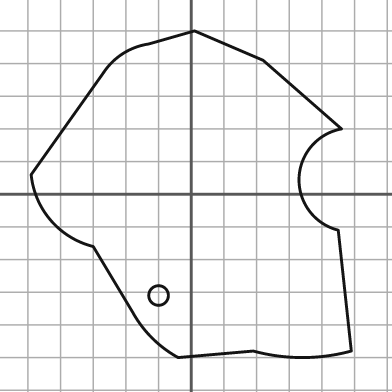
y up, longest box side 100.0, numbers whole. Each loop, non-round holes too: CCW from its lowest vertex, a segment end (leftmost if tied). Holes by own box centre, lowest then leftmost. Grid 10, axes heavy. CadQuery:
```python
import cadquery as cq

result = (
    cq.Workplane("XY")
    .moveTo(-4.0, -50.0)
    .lineTo(19.0, -48.0)
    .threePointArc((34.0, -50.0), (49.0, -48.0))
    .lineTo(45.0, -11.0)
    .threePointArc((33.0, 5.0), (46.0, 20.0))
    .lineTo(22.0, 41.0)
    .lineTo(1.0, 50.0)
    .lineTo(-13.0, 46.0)
    .threePointArc((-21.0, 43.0), (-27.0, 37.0))
    .lineTo(-49.0, 6.0)
    .threePointArc((-43.0, -8.0), (-30.0, -16.0))
    .lineTo(-18.0, -36.0)
    .threePointArc((-12.0, -44.0), (-4.0, -50.0))
    .close()
    .moveTo(-10.0, -31.0)
    .circle(3.0)
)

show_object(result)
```